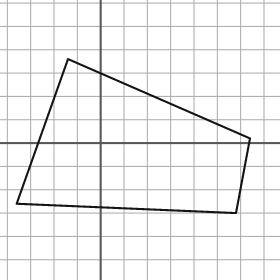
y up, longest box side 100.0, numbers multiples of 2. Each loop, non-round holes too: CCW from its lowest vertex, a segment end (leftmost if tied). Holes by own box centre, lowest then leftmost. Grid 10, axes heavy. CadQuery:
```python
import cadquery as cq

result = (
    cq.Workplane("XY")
    .moveTo(58.0, -30.0)
    .lineTo(64.0, 2.0)
    .lineTo(-14.0, 36.0)
    .lineTo(-36.0, -26.0)
    .close()
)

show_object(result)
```